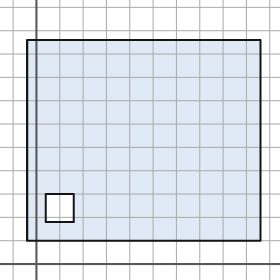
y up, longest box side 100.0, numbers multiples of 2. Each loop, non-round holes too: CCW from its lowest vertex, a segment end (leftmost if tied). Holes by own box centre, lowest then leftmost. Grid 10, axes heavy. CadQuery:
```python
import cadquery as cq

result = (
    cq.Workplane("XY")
    .moveTo(-4.0, 10.0)
    .lineTo(96.0, 10.0)
    .lineTo(96.0, 96.0)
    .lineTo(-4.0, 96.0)
    .close()
    .moveTo(4.0, 18.0)
    .lineTo(16.0, 18.0)
    .lineTo(16.0, 30.0)
    .lineTo(4.0, 30.0)
    .close()
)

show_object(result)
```